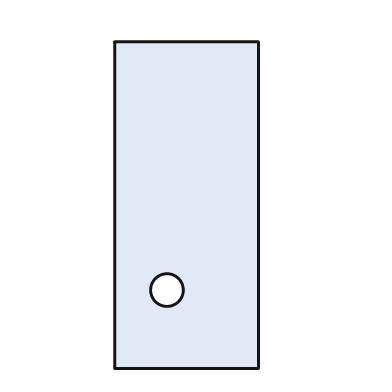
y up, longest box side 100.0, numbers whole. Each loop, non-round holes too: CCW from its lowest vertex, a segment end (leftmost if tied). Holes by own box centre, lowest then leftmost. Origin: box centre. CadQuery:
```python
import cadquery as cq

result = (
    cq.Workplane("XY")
    .moveTo(-22.0, -50.0)
    .lineTo(22.0, -50.0)
    .lineTo(22.0, 50.0)
    .lineTo(-22.0, 50.0)
    .close()
    .moveTo(-6.0, -26.0)
    .circle(5.0)
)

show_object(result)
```